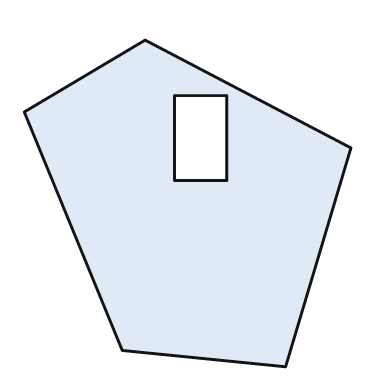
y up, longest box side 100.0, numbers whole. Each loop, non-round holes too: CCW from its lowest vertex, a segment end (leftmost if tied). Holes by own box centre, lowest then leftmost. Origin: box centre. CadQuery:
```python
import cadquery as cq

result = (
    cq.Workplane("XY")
    .moveTo(30.0, -50.0)
    .lineTo(50.0, 17.0)
    .lineTo(-13.0, 50.0)
    .lineTo(-50.0, 28.0)
    .lineTo(-20.0, -45.0)
    .close()
    .moveTo(-4.0, 7.0)
    .lineTo(12.0, 7.0)
    .lineTo(12.0, 33.0)
    .lineTo(-4.0, 33.0)
    .close()
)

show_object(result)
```